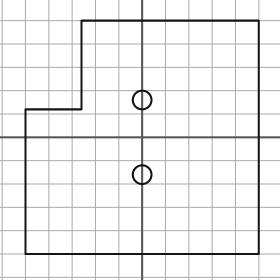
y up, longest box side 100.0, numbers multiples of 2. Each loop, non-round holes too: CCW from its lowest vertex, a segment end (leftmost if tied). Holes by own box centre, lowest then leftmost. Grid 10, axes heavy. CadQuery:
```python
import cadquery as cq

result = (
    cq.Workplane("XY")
    .moveTo(-50.0, -50.0)
    .lineTo(50.0, -50.0)
    .lineTo(50.0, 50.0)
    .lineTo(-26.0, 50.0)
    .lineTo(-26.0, 12.0)
    .lineTo(-50.0, 12.0)
    .close()
    .moveTo(0.0, -16.0)
    .circle(4.0)
    .moveTo(0.0, 16.0)
    .circle(4.0)
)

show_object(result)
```